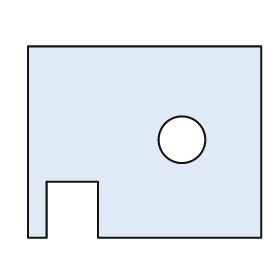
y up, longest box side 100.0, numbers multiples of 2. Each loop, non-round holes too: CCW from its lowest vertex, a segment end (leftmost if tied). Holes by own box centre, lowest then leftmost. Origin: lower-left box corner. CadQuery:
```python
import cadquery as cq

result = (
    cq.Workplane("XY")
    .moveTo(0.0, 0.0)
    .lineTo(8.0, 0.0)
    .lineTo(8.0, 24.0)
    .lineTo(30.0, 24.0)
    .lineTo(30.0, 0.0)
    .lineTo(100.0, 0.0)
    .lineTo(100.0, 82.0)
    .lineTo(0.0, 82.0)
    .close()
    .moveTo(66.0, 42.0)
    .circle(10.0)
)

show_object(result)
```